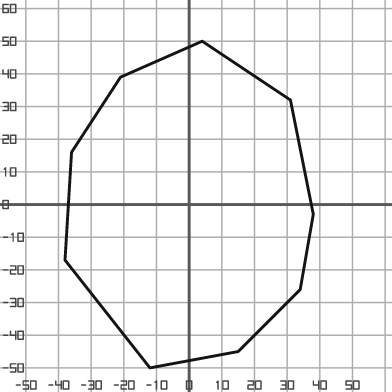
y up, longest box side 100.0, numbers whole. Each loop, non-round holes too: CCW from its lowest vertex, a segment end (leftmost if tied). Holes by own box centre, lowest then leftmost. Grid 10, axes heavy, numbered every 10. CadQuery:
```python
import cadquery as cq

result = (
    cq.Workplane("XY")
    .moveTo(-12.0, -50.0)
    .lineTo(15.0, -45.0)
    .lineTo(34.0, -26.0)
    .lineTo(38.0, -3.0)
    .lineTo(31.0, 32.0)
    .lineTo(4.0, 50.0)
    .lineTo(-21.0, 39.0)
    .lineTo(-36.0, 16.0)
    .lineTo(-38.0, -17.0)
    .close()
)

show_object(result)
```